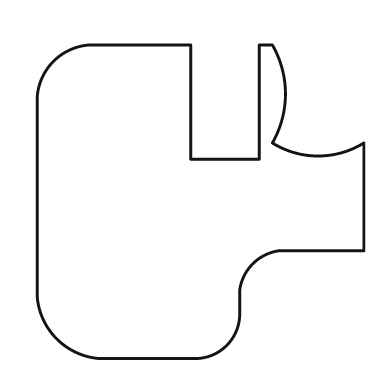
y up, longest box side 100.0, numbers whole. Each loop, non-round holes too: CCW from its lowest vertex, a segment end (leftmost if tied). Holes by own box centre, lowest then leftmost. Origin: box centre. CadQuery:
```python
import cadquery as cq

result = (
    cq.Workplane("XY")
    .moveTo(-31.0, -48.0)
    .lineTo(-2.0, -48.0)
    .threePointArc((8.0, -44.0), (12.0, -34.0))
    .lineTo(12.0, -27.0)
    .threePointArc((16.0, -19.0), (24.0, -15.0))
    .lineTo(50.0, -15.0)
    .lineTo(50.0, 18.0)
    .threePointArc((36.0, 14.0), (22.0, 18.0))
    .threePointArc((26.0, 33.0), (22.0, 48.0))
    .lineTo(18.0, 48.0)
    .lineTo(18.0, 13.0)
    .lineTo(-3.0, 13.0)
    .lineTo(-3.0, 48.0)
    .lineTo(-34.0, 48.0)
    .threePointArc((-45.0, 43.0), (-50.0, 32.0))
    .lineTo(-50.0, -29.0)
    .threePointArc((-44.0, -42.0), (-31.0, -48.0))
    .close()
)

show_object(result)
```